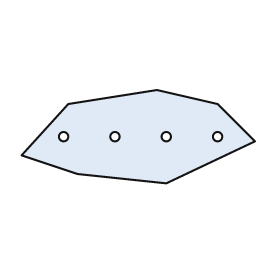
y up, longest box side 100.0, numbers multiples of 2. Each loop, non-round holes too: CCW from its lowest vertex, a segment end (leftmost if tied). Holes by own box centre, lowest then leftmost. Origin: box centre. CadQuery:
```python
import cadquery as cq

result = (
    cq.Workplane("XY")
    .moveTo(12.0, -20.0)
    .lineTo(50.0, -2.0)
    .lineTo(34.0, 14.0)
    .lineTo(8.0, 20.0)
    .lineTo(-30.0, 14.0)
    .lineTo(-50.0, -8.0)
    .lineTo(-26.0, -16.0)
    .close()
    .moveTo(-32.0, 0.0)
    .circle(2.0)
    .moveTo(-10.0, 0.0)
    .circle(2.0)
    .moveTo(12.0, 0.0)
    .circle(2.0)
    .moveTo(34.0, 0.0)
    .circle(2.0)
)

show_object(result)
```